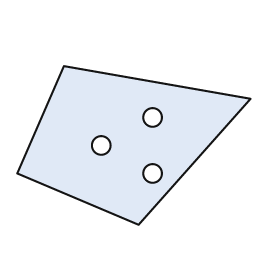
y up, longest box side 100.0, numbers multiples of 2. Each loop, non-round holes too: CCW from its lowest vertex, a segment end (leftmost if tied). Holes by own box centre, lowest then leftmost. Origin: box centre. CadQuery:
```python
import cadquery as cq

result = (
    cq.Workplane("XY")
    .moveTo(2.0, -34.0)
    .lineTo(50.0, 20.0)
    .lineTo(-30.0, 34.0)
    .lineTo(-50.0, -12.0)
    .close()
    .moveTo(8.0, -12.0)
    .circle(4.0)
    .moveTo(-14.0, 0.0)
    .circle(4.0)
    .moveTo(8.0, 12.0)
    .circle(4.0)
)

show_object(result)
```